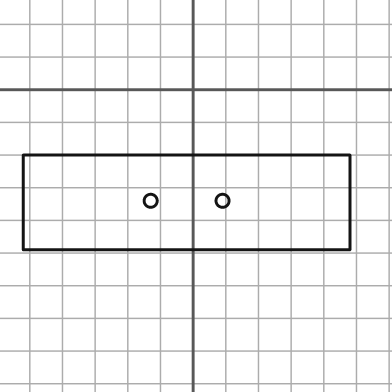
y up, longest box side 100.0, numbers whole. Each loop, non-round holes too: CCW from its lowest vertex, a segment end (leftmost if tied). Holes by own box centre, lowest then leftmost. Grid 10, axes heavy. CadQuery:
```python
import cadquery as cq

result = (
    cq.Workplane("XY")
    .moveTo(-52.0, -49.0)
    .lineTo(48.0, -49.0)
    .lineTo(48.0, -20.0)
    .lineTo(-52.0, -20.0)
    .close()
    .moveTo(-13.0, -34.0)
    .circle(2.0)
    .moveTo(9.0, -34.0)
    .circle(2.0)
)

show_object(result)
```